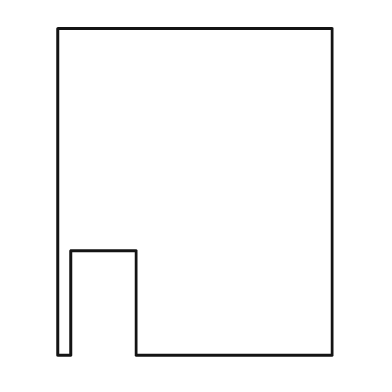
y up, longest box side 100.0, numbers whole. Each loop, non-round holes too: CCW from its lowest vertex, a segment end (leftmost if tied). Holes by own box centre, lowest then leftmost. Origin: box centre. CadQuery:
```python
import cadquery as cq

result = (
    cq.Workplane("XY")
    .moveTo(-42.0, -50.0)
    .lineTo(-38.0, -50.0)
    .lineTo(-38.0, -18.0)
    .lineTo(-18.0, -18.0)
    .lineTo(-18.0, -50.0)
    .lineTo(42.0, -50.0)
    .lineTo(42.0, 50.0)
    .lineTo(-42.0, 50.0)
    .close()
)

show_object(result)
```